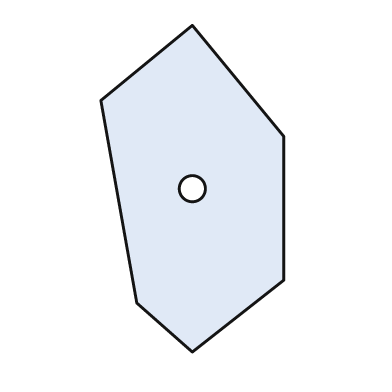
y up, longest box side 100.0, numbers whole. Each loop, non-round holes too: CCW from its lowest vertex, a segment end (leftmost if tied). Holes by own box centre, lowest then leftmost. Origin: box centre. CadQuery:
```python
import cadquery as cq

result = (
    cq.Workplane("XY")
    .moveTo(0.0, -50.0)
    .lineTo(28.0, -28.0)
    .lineTo(28.0, 16.0)
    .lineTo(0.0, 50.0)
    .lineTo(-28.0, 27.0)
    .lineTo(-17.0, -35.0)
    .close()
    .moveTo(0.0, 0.0)
    .circle(4.0)
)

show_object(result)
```